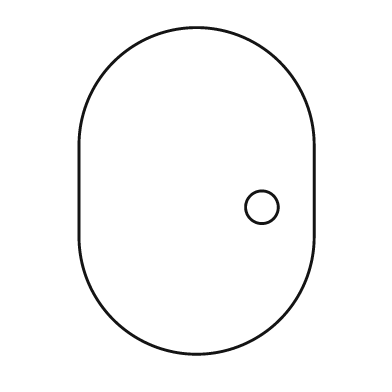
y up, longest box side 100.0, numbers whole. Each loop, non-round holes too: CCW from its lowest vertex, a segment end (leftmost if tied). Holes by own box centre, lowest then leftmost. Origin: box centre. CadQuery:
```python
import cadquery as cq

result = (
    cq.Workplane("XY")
    .moveTo(-36.0, -14.0)
    .threePointArc((0.0, -50.0), (36.0, -14.0))
    .lineTo(36.0, 14.0)
    .threePointArc((0.0, 50.0), (-36.0, 14.0))
    .close()
    .moveTo(20.0, -5.0)
    .circle(5.0)
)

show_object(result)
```